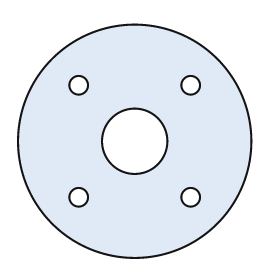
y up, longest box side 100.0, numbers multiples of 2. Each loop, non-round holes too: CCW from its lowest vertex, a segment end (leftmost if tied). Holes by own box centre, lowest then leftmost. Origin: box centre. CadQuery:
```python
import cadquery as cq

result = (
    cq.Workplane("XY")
    .moveTo(0.0, 0.0)
    .circle(50.0)
    .moveTo(-24.0, -24.0)
    .circle(4.0)
    .moveTo(24.0, -24.0)
    .circle(4.0)
    .moveTo(0.0, 0.0)
    .circle(14.0)
    .moveTo(-24.0, 24.0)
    .circle(4.0)
    .moveTo(24.0, 24.0)
    .circle(4.0)
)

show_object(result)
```